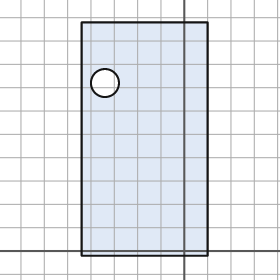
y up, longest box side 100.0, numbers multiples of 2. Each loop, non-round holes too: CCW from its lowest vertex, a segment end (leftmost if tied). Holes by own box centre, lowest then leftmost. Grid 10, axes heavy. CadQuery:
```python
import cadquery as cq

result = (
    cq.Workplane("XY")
    .moveTo(-44.0, -2.0)
    .lineTo(10.0, -2.0)
    .lineTo(10.0, 98.0)
    .lineTo(-44.0, 98.0)
    .close()
    .moveTo(-34.0, 72.0)
    .circle(6.0)
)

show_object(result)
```